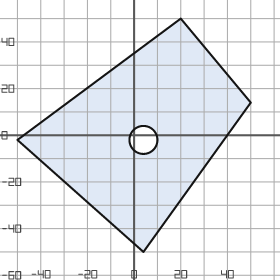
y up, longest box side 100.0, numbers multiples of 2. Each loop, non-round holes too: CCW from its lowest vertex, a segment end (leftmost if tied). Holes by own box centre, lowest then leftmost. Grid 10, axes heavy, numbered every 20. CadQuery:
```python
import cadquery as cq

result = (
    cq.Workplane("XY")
    .moveTo(4.0, -50.0)
    .lineTo(50.0, 14.0)
    .lineTo(20.0, 50.0)
    .lineTo(-50.0, -2.0)
    .close()
    .moveTo(4.0, -2.0)
    .circle(6.0)
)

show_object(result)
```